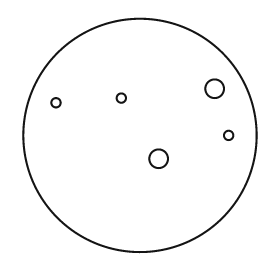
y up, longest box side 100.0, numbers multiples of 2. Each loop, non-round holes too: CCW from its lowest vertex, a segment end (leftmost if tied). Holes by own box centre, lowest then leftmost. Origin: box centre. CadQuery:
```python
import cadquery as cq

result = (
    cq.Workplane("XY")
    .moveTo(0.0, 0.0)
    .circle(50.0)
    .moveTo(8.0, -10.0)
    .circle(4.0)
    .moveTo(38.0, 0.0)
    .circle(2.0)
    .moveTo(-36.0, 14.0)
    .circle(2.0)
    .moveTo(-8.0, 16.0)
    .circle(2.0)
    .moveTo(32.0, 20.0)
    .circle(4.0)
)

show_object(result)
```